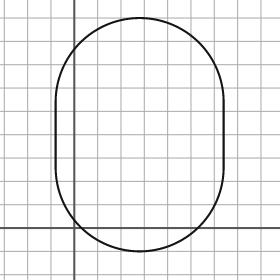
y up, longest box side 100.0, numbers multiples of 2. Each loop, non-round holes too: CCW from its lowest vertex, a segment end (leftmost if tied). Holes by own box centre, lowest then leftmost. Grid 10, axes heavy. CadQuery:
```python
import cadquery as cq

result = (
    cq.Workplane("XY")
    .moveTo(-8.0, 26.0)
    .threePointArc((28.0, -10.0), (64.0, 26.0))
    .lineTo(64.0, 54.0)
    .threePointArc((28.0, 90.0), (-8.0, 54.0))
    .close()
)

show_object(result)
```